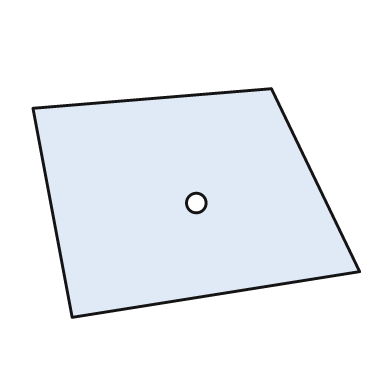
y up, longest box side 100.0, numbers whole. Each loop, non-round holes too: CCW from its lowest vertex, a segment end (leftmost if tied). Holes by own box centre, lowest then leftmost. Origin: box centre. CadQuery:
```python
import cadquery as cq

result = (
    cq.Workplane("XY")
    .moveTo(-38.0, -35.0)
    .lineTo(50.0, -21.0)
    .lineTo(23.0, 35.0)
    .lineTo(-50.0, 29.0)
    .close()
    .moveTo(0.0, 0.0)
    .circle(3.0)
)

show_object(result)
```